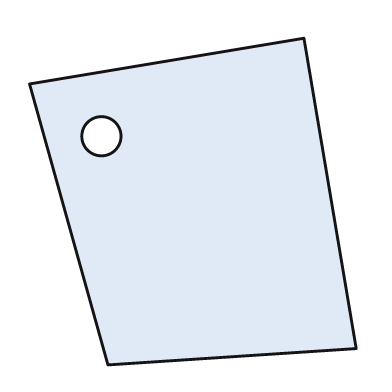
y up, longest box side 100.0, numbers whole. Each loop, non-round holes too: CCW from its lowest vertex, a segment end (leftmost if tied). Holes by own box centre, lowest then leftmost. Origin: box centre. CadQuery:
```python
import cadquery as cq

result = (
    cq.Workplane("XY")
    .moveTo(-26.0, -50.0)
    .lineTo(50.0, -45.0)
    .lineTo(34.0, 50.0)
    .lineTo(-50.0, 36.0)
    .close()
    .moveTo(-28.0, 20.0)
    .circle(6.0)
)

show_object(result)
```